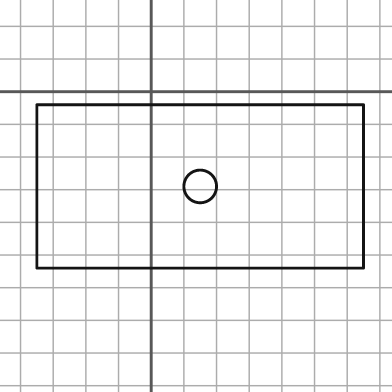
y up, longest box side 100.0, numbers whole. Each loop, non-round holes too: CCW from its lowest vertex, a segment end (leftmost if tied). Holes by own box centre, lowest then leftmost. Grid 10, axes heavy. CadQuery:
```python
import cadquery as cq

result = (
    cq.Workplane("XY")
    .moveTo(-35.0, -54.0)
    .lineTo(65.0, -54.0)
    .lineTo(65.0, -4.0)
    .lineTo(-35.0, -4.0)
    .close()
    .moveTo(15.0, -29.0)
    .circle(5.0)
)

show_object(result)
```